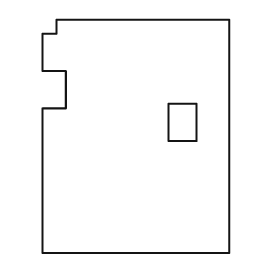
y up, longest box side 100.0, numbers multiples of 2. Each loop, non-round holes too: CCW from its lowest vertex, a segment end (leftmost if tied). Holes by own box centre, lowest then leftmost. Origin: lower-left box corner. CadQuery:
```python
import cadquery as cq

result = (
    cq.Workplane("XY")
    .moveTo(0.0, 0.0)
    .lineTo(80.0, 0.0)
    .lineTo(80.0, 100.0)
    .lineTo(6.0, 100.0)
    .lineTo(6.0, 94.0)
    .lineTo(0.0, 94.0)
    .lineTo(0.0, 78.0)
    .lineTo(10.0, 78.0)
    .lineTo(10.0, 62.0)
    .lineTo(0.0, 62.0)
    .close()
    .moveTo(54.0, 48.0)
    .lineTo(66.0, 48.0)
    .lineTo(66.0, 64.0)
    .lineTo(54.0, 64.0)
    .close()
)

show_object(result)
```